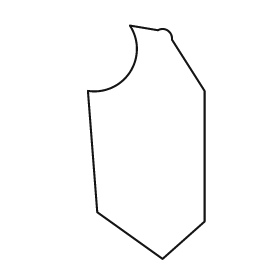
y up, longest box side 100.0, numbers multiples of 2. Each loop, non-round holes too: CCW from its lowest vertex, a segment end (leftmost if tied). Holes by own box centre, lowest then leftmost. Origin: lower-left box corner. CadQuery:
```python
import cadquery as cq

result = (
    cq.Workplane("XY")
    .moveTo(32.0, 0.0)
    .lineTo(50.0, 16.0)
    .lineTo(50.0, 72.0)
    .lineTo(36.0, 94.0)
    .threePointArc((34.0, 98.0), (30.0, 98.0))
    .lineTo(18.0, 100.0)
    .threePointArc((18.0, 80.0), (0.0, 72.0))
    .lineTo(4.0, 20.0)
    .close()
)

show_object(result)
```